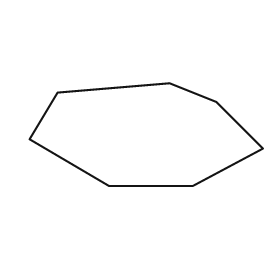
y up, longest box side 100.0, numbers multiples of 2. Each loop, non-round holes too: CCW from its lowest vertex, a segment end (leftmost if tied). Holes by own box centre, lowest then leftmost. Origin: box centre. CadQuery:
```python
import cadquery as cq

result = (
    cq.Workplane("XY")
    .moveTo(-16.0, -22.0)
    .lineTo(20.0, -22.0)
    .lineTo(50.0, -6.0)
    .lineTo(30.0, 14.0)
    .lineTo(10.0, 22.0)
    .lineTo(-38.0, 18.0)
    .lineTo(-50.0, -2.0)
    .close()
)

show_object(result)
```